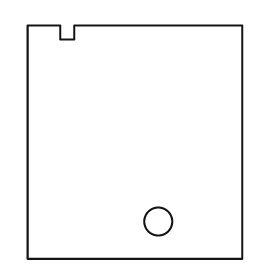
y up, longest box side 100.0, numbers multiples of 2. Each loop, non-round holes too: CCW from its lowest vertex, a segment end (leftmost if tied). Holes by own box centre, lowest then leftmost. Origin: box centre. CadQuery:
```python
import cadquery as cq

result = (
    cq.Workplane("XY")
    .moveTo(-46.0, -50.0)
    .lineTo(46.0, -50.0)
    .lineTo(46.0, 50.0)
    .lineTo(-26.0, 50.0)
    .lineTo(-26.0, 44.0)
    .lineTo(-32.0, 44.0)
    .lineTo(-32.0, 50.0)
    .lineTo(-46.0, 50.0)
    .close()
    .moveTo(10.0, -34.0)
    .circle(6.0)
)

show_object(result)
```